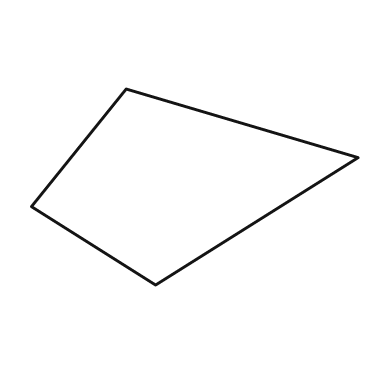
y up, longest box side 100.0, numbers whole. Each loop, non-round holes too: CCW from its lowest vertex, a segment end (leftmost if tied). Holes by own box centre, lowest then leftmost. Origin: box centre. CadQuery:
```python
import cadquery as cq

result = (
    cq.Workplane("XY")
    .moveTo(-12.0, -30.0)
    .lineTo(50.0, 9.0)
    .lineTo(-21.0, 30.0)
    .lineTo(-50.0, -6.0)
    .close()
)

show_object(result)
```